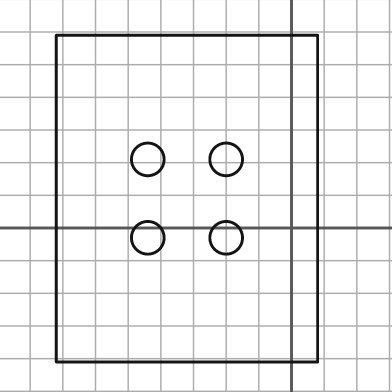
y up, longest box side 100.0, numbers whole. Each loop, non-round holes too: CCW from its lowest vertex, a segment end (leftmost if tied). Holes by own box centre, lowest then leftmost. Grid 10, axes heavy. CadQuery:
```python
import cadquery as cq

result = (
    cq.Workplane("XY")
    .moveTo(-72.0, -41.0)
    .lineTo(8.0, -41.0)
    .lineTo(8.0, 59.0)
    .lineTo(-72.0, 59.0)
    .close()
    .moveTo(-44.0, -3.0)
    .circle(5.0)
    .moveTo(-20.0, -3.0)
    .circle(5.0)
    .moveTo(-44.0, 21.0)
    .circle(5.0)
    .moveTo(-20.0, 21.0)
    .circle(5.0)
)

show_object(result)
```